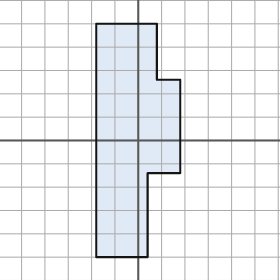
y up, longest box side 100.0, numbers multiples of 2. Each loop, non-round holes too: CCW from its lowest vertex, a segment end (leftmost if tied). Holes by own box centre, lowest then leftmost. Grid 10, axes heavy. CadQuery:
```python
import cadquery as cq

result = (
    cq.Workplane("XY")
    .moveTo(-18.0, -50.0)
    .lineTo(4.0, -50.0)
    .lineTo(4.0, -14.0)
    .lineTo(18.0, -14.0)
    .lineTo(18.0, 26.0)
    .lineTo(8.0, 26.0)
    .lineTo(8.0, 50.0)
    .lineTo(-18.0, 50.0)
    .close()
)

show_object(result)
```